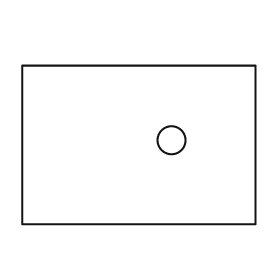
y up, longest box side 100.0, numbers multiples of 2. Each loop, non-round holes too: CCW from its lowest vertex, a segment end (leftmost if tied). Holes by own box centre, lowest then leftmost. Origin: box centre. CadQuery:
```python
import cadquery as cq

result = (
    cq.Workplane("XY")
    .moveTo(-50.0, -34.0)
    .lineTo(50.0, -34.0)
    .lineTo(50.0, 34.0)
    .lineTo(-50.0, 34.0)
    .close()
    .moveTo(14.0, 2.0)
    .circle(6.0)
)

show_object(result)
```